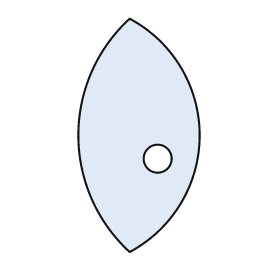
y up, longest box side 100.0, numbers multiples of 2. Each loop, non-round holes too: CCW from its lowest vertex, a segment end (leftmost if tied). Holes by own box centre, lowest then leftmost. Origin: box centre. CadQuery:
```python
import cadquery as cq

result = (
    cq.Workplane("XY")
    .moveTo(-4.0, -50.0)
    .threePointArc((26.0, 0.0), (-4.0, 50.0))
    .threePointArc((-26.0, 0.0), (-4.0, -50.0))
    .close()
    .moveTo(8.0, -10.0)
    .circle(6.0)
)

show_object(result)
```